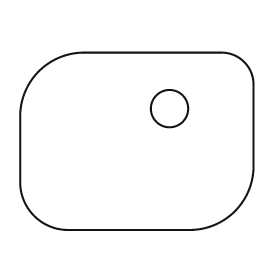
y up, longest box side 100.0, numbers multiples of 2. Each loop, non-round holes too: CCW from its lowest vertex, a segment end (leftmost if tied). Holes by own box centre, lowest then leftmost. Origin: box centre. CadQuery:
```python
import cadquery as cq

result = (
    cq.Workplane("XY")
    .moveTo(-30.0, -38.0)
    .lineTo(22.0, -38.0)
    .threePointArc((42.0, -30.0), (50.0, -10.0))
    .lineTo(50.0, 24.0)
    .threePointArc((46.0, 34.0), (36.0, 38.0))
    .lineTo(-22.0, 38.0)
    .threePointArc((-42.0, 30.0), (-50.0, 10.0))
    .lineTo(-50.0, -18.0)
    .threePointArc((-44.0, -32.0), (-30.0, -38.0))
    .close()
    .moveTo(14.0, 14.0)
    .circle(8.0)
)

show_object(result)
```